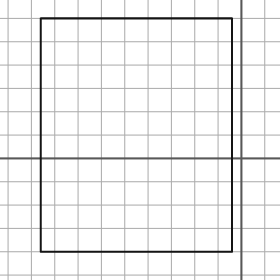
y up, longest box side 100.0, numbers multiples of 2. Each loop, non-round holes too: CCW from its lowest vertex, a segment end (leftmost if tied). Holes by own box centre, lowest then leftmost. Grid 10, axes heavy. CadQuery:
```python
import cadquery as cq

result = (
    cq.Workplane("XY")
    .moveTo(-86.0, -40.0)
    .lineTo(-4.0, -40.0)
    .lineTo(-4.0, 60.0)
    .lineTo(-86.0, 60.0)
    .close()
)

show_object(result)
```